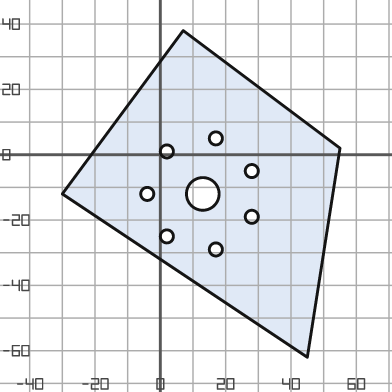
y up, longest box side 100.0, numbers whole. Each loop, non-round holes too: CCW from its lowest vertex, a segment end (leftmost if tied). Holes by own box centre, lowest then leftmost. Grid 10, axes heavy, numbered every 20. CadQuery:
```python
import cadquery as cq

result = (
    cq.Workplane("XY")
    .moveTo(45.0, -62.0)
    .lineTo(55.0, 2.0)
    .lineTo(7.0, 38.0)
    .lineTo(-30.0, -12.0)
    .close()
    .moveTo(17.0, -29.0)
    .circle(2.0)
    .moveTo(2.0, -25.0)
    .circle(2.0)
    .moveTo(28.0, -19.0)
    .circle(2.0)
    .moveTo(-4.0, -12.0)
    .circle(2.0)
    .moveTo(13.0, -12.0)
    .circle(5.0)
    .moveTo(28.0, -5.0)
    .circle(2.0)
    .moveTo(2.0, 1.0)
    .circle(2.0)
    .moveTo(17.0, 5.0)
    .circle(2.0)
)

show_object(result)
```